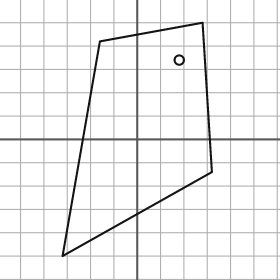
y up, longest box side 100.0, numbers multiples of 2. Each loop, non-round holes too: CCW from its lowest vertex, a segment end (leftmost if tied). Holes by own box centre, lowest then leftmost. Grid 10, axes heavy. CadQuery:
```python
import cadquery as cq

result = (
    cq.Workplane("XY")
    .moveTo(-32.0, -50.0)
    .lineTo(32.0, -14.0)
    .lineTo(28.0, 50.0)
    .lineTo(-16.0, 42.0)
    .close()
    .moveTo(18.0, 34.0)
    .circle(2.0)
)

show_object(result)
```